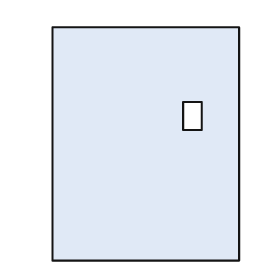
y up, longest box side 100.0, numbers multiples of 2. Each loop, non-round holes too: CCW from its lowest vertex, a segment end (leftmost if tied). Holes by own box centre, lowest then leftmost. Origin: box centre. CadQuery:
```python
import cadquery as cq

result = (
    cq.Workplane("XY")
    .moveTo(-40.0, -50.0)
    .lineTo(40.0, -50.0)
    .lineTo(40.0, 50.0)
    .lineTo(-40.0, 50.0)
    .close()
    .moveTo(16.0, 6.0)
    .lineTo(24.0, 6.0)
    .lineTo(24.0, 18.0)
    .lineTo(16.0, 18.0)
    .close()
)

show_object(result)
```